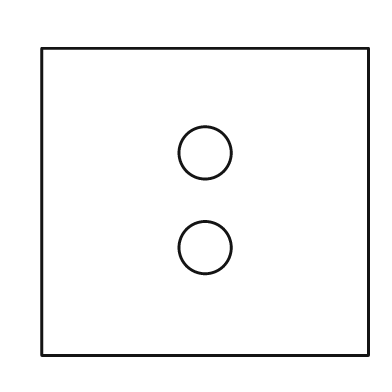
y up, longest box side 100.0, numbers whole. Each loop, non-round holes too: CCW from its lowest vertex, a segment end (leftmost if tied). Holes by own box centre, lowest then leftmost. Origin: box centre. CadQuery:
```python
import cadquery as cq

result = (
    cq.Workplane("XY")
    .moveTo(-50.0, -47.0)
    .lineTo(50.0, -47.0)
    .lineTo(50.0, 47.0)
    .lineTo(-50.0, 47.0)
    .close()
    .moveTo(0.0, -14.0)
    .circle(8.0)
    .moveTo(0.0, 15.0)
    .circle(8.0)
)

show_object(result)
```